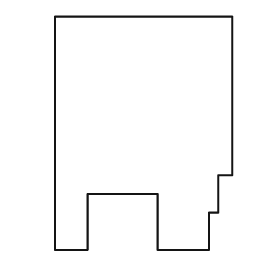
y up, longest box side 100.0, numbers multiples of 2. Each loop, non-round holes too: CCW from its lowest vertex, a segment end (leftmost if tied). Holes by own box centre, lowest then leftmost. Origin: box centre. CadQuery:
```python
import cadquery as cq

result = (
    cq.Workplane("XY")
    .moveTo(-38.0, -50.0)
    .lineTo(-24.0, -50.0)
    .lineTo(-24.0, -26.0)
    .lineTo(6.0, -26.0)
    .lineTo(6.0, -50.0)
    .lineTo(28.0, -50.0)
    .lineTo(28.0, -34.0)
    .lineTo(32.0, -34.0)
    .lineTo(32.0, -18.0)
    .lineTo(38.0, -18.0)
    .lineTo(38.0, 50.0)
    .lineTo(-38.0, 50.0)
    .close()
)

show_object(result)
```